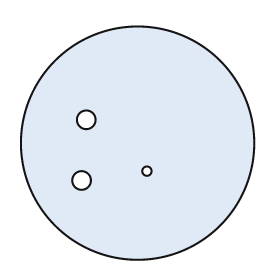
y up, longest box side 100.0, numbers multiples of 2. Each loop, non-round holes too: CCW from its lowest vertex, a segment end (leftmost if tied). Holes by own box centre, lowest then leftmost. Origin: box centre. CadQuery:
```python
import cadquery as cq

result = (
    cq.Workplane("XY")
    .moveTo(0.0, 0.0)
    .circle(50.0)
    .moveTo(-24.0, -16.0)
    .circle(4.0)
    .moveTo(4.0, -12.0)
    .circle(2.0)
    .moveTo(-22.0, 10.0)
    .circle(4.0)
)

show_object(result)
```